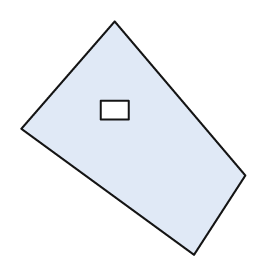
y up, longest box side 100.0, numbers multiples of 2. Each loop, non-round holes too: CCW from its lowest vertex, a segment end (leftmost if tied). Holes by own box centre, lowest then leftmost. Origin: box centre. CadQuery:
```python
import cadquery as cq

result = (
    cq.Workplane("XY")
    .moveTo(26.0, -50.0)
    .lineTo(48.0, -16.0)
    .lineTo(-8.0, 50.0)
    .lineTo(-48.0, 4.0)
    .close()
    .moveTo(-14.0, 8.0)
    .lineTo(-2.0, 8.0)
    .lineTo(-2.0, 16.0)
    .lineTo(-14.0, 16.0)
    .close()
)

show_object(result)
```